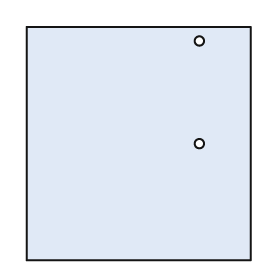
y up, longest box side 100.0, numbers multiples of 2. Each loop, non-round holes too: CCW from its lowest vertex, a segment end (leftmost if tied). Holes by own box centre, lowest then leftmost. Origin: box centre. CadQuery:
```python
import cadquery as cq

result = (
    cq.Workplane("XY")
    .moveTo(-48.0, -50.0)
    .lineTo(48.0, -50.0)
    .lineTo(48.0, 50.0)
    .lineTo(-48.0, 50.0)
    .close()
    .moveTo(26.0, 0.0)
    .circle(2.0)
    .moveTo(26.0, 44.0)
    .circle(2.0)
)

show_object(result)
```